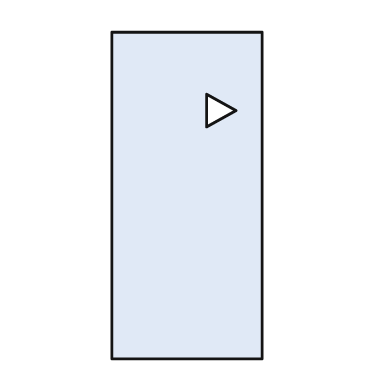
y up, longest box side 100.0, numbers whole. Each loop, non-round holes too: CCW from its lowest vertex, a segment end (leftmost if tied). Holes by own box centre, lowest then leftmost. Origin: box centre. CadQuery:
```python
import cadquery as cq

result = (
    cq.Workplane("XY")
    .moveTo(-23.0, -50.0)
    .lineTo(23.0, -50.0)
    .lineTo(23.0, 50.0)
    .lineTo(-23.0, 50.0)
    .close()
    .moveTo(6.0, 21.0)
    .lineTo(15.0, 26.0)
    .lineTo(6.0, 31.0)
    .close()
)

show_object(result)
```